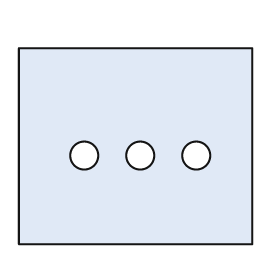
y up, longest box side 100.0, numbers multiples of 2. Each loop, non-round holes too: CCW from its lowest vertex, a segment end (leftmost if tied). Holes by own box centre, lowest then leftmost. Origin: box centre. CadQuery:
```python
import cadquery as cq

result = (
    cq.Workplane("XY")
    .moveTo(-50.0, -42.0)
    .lineTo(50.0, -42.0)
    .lineTo(50.0, 42.0)
    .lineTo(-50.0, 42.0)
    .close()
    .moveTo(-22.0, -4.0)
    .circle(6.0)
    .moveTo(2.0, -4.0)
    .circle(6.0)
    .moveTo(26.0, -4.0)
    .circle(6.0)
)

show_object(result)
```